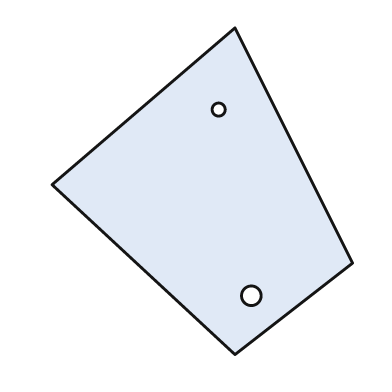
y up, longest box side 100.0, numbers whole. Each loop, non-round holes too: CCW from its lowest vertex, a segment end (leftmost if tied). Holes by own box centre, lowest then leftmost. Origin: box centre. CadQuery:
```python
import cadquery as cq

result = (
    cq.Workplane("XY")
    .moveTo(10.0, -50.0)
    .lineTo(46.0, -22.0)
    .lineTo(10.0, 50.0)
    .lineTo(-46.0, 2.0)
    .close()
    .moveTo(15.0, -32.0)
    .circle(3.0)
    .moveTo(5.0, 25.0)
    .circle(2.0)
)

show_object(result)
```